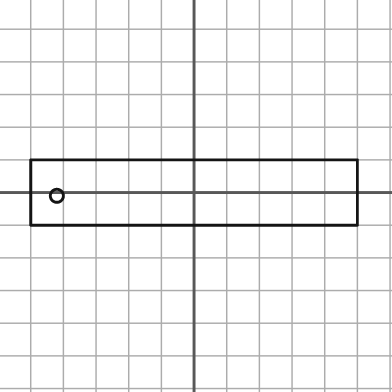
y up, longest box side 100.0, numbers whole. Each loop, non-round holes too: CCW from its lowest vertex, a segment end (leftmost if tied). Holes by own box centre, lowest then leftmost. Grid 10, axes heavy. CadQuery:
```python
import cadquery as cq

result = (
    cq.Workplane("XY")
    .moveTo(-50.0, -10.0)
    .lineTo(50.0, -10.0)
    .lineTo(50.0, 10.0)
    .lineTo(-50.0, 10.0)
    .close()
    .moveTo(-42.0, -1.0)
    .circle(2.0)
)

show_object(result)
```